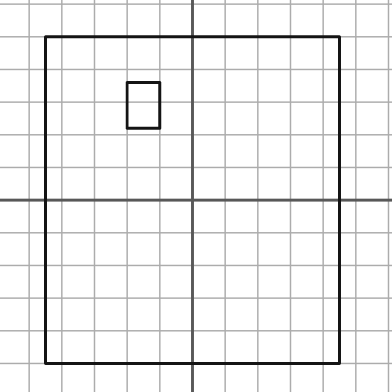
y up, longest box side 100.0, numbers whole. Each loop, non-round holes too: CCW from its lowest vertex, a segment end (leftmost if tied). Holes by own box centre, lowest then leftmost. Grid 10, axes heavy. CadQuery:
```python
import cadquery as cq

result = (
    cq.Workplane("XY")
    .moveTo(-45.0, -50.0)
    .lineTo(45.0, -50.0)
    .lineTo(45.0, 50.0)
    .lineTo(-45.0, 50.0)
    .close()
    .moveTo(-20.0, 22.0)
    .lineTo(-10.0, 22.0)
    .lineTo(-10.0, 36.0)
    .lineTo(-20.0, 36.0)
    .close()
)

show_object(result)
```